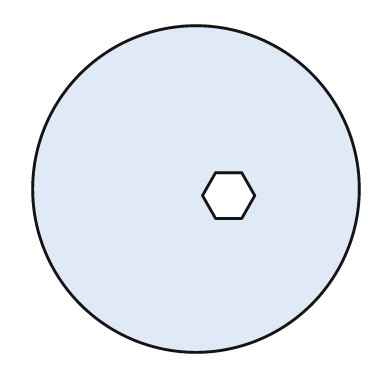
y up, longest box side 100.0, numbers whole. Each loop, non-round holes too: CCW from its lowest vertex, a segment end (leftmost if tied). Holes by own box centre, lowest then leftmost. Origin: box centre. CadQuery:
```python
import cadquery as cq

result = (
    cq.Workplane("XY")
    .moveTo(0.0, 0.0)
    .circle(50.0)
    .moveTo(6.0, -9.0)
    .lineTo(14.0, -9.0)
    .lineTo(18.0, -2.0)
    .lineTo(14.0, 5.0)
    .lineTo(6.0, 5.0)
    .lineTo(2.0, -2.0)
    .close()
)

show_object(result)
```